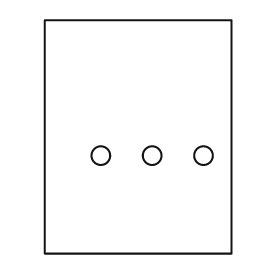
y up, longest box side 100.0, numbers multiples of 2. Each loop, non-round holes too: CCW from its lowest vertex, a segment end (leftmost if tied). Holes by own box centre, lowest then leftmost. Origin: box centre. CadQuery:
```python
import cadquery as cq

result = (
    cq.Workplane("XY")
    .moveTo(-40.0, -50.0)
    .lineTo(40.0, -50.0)
    .lineTo(40.0, 50.0)
    .lineTo(-40.0, 50.0)
    .close()
    .moveTo(-16.0, -8.0)
    .circle(4.0)
    .moveTo(6.0, -8.0)
    .circle(4.0)
    .moveTo(28.0, -8.0)
    .circle(4.0)
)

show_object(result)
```